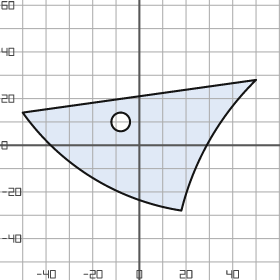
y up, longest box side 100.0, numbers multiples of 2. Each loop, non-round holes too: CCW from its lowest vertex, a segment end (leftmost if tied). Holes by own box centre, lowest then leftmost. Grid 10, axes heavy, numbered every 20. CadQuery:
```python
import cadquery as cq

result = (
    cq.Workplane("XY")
    .moveTo(18.0, -28.0)
    .threePointArc((30.0, 2.0), (50.0, 28.0))
    .lineTo(-50.0, 14.0)
    .threePointArc((-20.0, -14.0), (18.0, -28.0))
    .close()
    .moveTo(-8.0, 10.0)
    .circle(4.0)
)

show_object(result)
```